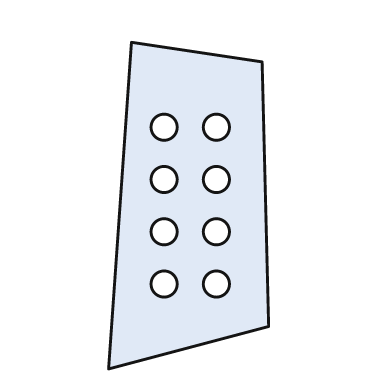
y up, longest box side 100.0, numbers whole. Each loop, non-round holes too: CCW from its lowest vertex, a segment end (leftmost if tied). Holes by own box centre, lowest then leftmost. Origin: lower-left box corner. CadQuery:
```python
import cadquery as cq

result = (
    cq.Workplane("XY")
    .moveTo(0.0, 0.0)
    .lineTo(49.0, 13.0)
    .lineTo(47.0, 94.0)
    .lineTo(7.0, 100.0)
    .close()
    .moveTo(17.0, 26.0)
    .circle(4.0)
    .moveTo(33.0, 26.0)
    .circle(4.0)
    .moveTo(17.0, 42.0)
    .circle(4.0)
    .moveTo(33.0, 42.0)
    .circle(4.0)
    .moveTo(17.0, 58.0)
    .circle(4.0)
    .moveTo(33.0, 58.0)
    .circle(4.0)
    .moveTo(17.0, 74.0)
    .circle(4.0)
    .moveTo(33.0, 74.0)
    .circle(4.0)
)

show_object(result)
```